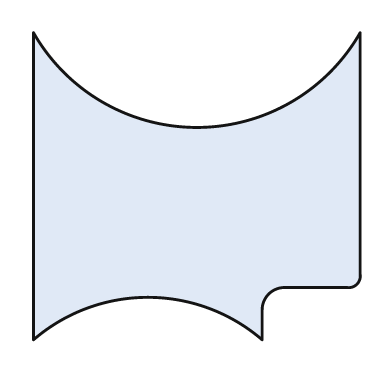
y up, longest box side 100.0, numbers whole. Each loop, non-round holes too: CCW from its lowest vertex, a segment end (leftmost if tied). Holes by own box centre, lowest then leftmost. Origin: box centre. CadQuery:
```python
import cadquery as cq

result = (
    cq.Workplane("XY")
    .moveTo(-50.0, -47.0)
    .threePointArc((-15.0, -34.0), (20.0, -47.0))
    .lineTo(20.0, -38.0)
    .threePointArc((22.0, -33.0), (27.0, -31.0))
    .lineTo(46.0, -31.0)
    .threePointArc((49.0, -30.0), (50.0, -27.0))
    .lineTo(50.0, 47.0)
    .threePointArc((0.0, 18.0), (-50.0, 47.0))
    .close()
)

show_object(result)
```